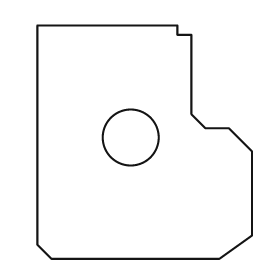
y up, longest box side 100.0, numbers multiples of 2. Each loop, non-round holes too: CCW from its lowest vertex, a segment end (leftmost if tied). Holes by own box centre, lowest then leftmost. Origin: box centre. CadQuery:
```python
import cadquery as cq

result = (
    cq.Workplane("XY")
    .moveTo(-40.0, -50.0)
    .lineTo(32.0, -50.0)
    .lineTo(46.0, -40.0)
    .lineTo(46.0, -4.0)
    .lineTo(36.0, 6.0)
    .lineTo(26.0, 6.0)
    .lineTo(20.0, 12.0)
    .lineTo(20.0, 46.0)
    .lineTo(14.0, 46.0)
    .lineTo(14.0, 50.0)
    .lineTo(-46.0, 50.0)
    .lineTo(-46.0, -44.0)
    .close()
    .moveTo(-6.0, 2.0)
    .circle(12.0)
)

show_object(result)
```